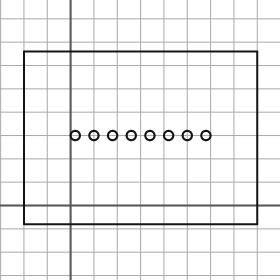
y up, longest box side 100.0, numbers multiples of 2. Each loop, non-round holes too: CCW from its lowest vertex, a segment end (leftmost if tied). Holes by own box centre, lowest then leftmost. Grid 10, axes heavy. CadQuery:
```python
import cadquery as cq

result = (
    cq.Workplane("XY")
    .moveTo(-20.0, -8.0)
    .lineTo(80.0, -8.0)
    .lineTo(80.0, 66.0)
    .lineTo(-20.0, 66.0)
    .close()
    .moveTo(2.0, 30.0)
    .circle(2.0)
    .moveTo(10.0, 30.0)
    .circle(2.0)
    .moveTo(18.0, 30.0)
    .circle(2.0)
    .moveTo(26.0, 30.0)
    .circle(2.0)
    .moveTo(34.0, 30.0)
    .circle(2.0)
    .moveTo(42.0, 30.0)
    .circle(2.0)
    .moveTo(50.0, 30.0)
    .circle(2.0)
    .moveTo(58.0, 30.0)
    .circle(2.0)
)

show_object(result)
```